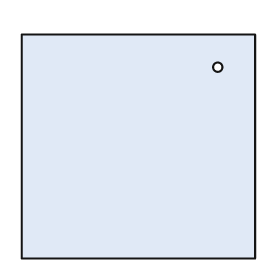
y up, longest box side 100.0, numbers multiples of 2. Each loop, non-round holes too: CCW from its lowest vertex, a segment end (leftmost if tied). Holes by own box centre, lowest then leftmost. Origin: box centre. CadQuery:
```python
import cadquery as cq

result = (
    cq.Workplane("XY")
    .moveTo(-50.0, -48.0)
    .lineTo(50.0, -48.0)
    .lineTo(50.0, 48.0)
    .lineTo(-50.0, 48.0)
    .close()
    .moveTo(34.0, 34.0)
    .circle(2.0)
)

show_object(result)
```